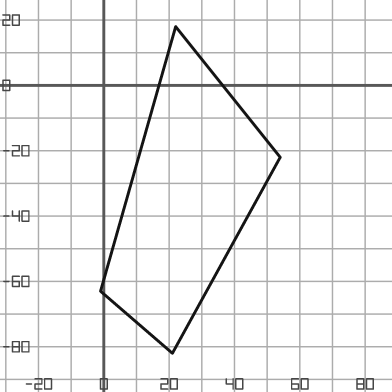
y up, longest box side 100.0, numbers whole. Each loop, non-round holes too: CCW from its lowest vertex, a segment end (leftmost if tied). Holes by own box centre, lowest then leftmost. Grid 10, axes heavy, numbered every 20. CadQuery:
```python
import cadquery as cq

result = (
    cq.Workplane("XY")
    .moveTo(21.0, -82.0)
    .lineTo(54.0, -22.0)
    .lineTo(22.0, 18.0)
    .lineTo(-1.0, -63.0)
    .close()
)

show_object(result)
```